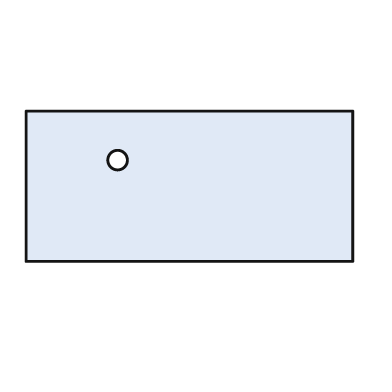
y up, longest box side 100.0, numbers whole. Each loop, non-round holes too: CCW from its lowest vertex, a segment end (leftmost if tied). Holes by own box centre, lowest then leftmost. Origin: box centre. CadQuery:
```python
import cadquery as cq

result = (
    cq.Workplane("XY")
    .moveTo(-50.0, -23.0)
    .lineTo(50.0, -23.0)
    .lineTo(50.0, 23.0)
    .lineTo(-50.0, 23.0)
    .close()
    .moveTo(-22.0, 8.0)
    .circle(3.0)
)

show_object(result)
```